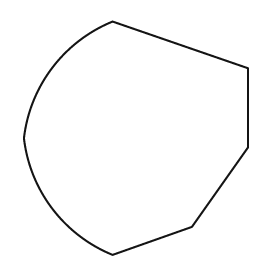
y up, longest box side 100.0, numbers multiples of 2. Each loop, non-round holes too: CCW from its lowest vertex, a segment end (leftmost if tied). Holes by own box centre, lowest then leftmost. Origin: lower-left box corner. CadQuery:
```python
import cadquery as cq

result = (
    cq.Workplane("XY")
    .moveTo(38.0, 0.0)
    .lineTo(72.0, 12.0)
    .lineTo(96.0, 46.0)
    .lineTo(96.0, 80.0)
    .lineTo(38.0, 100.0)
    .threePointArc((12.0, 80.0), (0.0, 50.0))
    .threePointArc((12.0, 20.0), (38.0, 0.0))
    .close()
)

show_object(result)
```